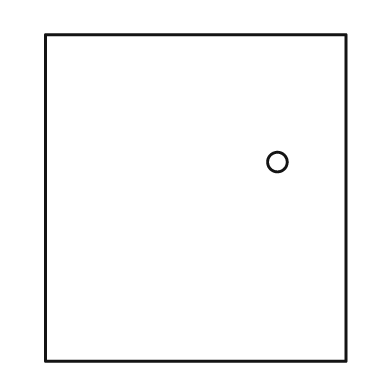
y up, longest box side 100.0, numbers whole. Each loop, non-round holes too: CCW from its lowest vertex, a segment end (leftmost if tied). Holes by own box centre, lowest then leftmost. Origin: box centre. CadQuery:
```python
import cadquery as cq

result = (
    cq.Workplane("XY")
    .moveTo(-46.0, -50.0)
    .lineTo(46.0, -50.0)
    .lineTo(46.0, 50.0)
    .lineTo(-46.0, 50.0)
    .close()
    .moveTo(25.0, 11.0)
    .circle(3.0)
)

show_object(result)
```